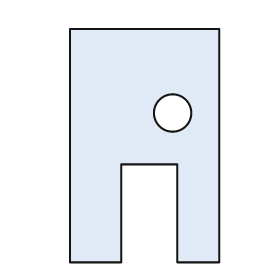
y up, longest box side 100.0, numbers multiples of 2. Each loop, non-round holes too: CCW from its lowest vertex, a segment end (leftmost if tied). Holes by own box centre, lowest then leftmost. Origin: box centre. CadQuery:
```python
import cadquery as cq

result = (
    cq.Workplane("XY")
    .moveTo(-32.0, -50.0)
    .lineTo(-10.0, -50.0)
    .lineTo(-10.0, -8.0)
    .lineTo(14.0, -8.0)
    .lineTo(14.0, -50.0)
    .lineTo(32.0, -50.0)
    .lineTo(32.0, 50.0)
    .lineTo(-32.0, 50.0)
    .close()
    .moveTo(12.0, 14.0)
    .circle(8.0)
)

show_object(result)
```